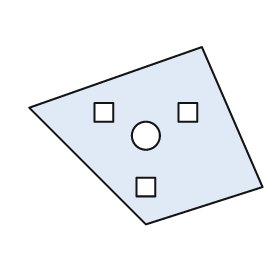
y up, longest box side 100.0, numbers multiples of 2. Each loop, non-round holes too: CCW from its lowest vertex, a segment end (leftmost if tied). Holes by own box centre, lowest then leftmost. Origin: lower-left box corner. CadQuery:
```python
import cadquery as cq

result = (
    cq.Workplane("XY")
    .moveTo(50.0, 0.0)
    .lineTo(100.0, 16.0)
    .lineTo(74.0, 76.0)
    .lineTo(0.0, 50.0)
    .close()
    .moveTo(46.0, 12.0)
    .lineTo(54.0, 12.0)
    .lineTo(54.0, 20.0)
    .lineTo(46.0, 20.0)
    .close()
    .moveTo(50.0, 38.0)
    .circle(6.0)
    .moveTo(28.0, 44.0)
    .lineTo(36.0, 44.0)
    .lineTo(36.0, 52.0)
    .lineTo(28.0, 52.0)
    .close()
    .moveTo(64.0, 44.0)
    .lineTo(72.0, 44.0)
    .lineTo(72.0, 52.0)
    .lineTo(64.0, 52.0)
    .close()
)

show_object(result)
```